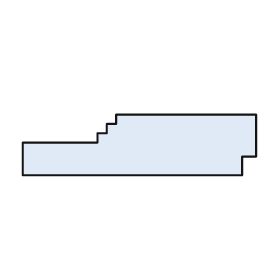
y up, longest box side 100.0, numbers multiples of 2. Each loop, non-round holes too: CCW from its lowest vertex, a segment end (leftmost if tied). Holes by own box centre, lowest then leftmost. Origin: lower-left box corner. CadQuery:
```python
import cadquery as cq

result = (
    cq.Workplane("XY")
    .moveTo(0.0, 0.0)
    .lineTo(94.0, 0.0)
    .lineTo(94.0, 8.0)
    .lineTo(100.0, 8.0)
    .lineTo(100.0, 26.0)
    .lineTo(40.0, 26.0)
    .lineTo(40.0, 22.0)
    .lineTo(36.0, 22.0)
    .lineTo(36.0, 18.0)
    .lineTo(32.0, 18.0)
    .lineTo(32.0, 14.0)
    .lineTo(0.0, 14.0)
    .close()
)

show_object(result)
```